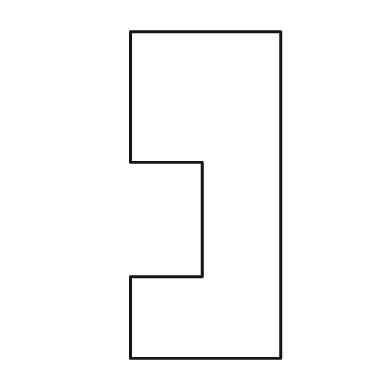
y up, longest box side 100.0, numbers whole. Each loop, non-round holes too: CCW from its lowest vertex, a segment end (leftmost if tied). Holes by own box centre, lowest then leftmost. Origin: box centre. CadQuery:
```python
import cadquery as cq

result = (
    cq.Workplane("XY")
    .moveTo(-23.0, -50.0)
    .lineTo(23.0, -50.0)
    .lineTo(23.0, 50.0)
    .lineTo(-23.0, 50.0)
    .lineTo(-23.0, 10.0)
    .lineTo(-1.0, 10.0)
    .lineTo(-1.0, -25.0)
    .lineTo(-23.0, -25.0)
    .close()
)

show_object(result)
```